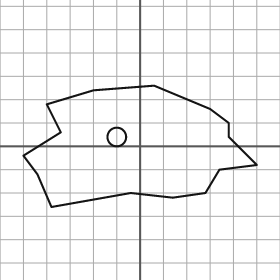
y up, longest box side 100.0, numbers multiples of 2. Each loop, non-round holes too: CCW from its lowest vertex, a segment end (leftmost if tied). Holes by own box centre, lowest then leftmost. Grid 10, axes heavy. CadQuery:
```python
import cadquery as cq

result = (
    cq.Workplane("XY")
    .moveTo(-38.0, -26.0)
    .lineTo(-4.0, -20.0)
    .lineTo(14.0, -22.0)
    .lineTo(28.0, -20.0)
    .lineTo(34.0, -10.0)
    .lineTo(50.0, -8.0)
    .lineTo(38.0, 4.0)
    .lineTo(38.0, 10.0)
    .lineTo(30.0, 16.0)
    .lineTo(6.0, 26.0)
    .lineTo(-20.0, 24.0)
    .lineTo(-40.0, 18.0)
    .lineTo(-34.0, 6.0)
    .lineTo(-50.0, -4.0)
    .lineTo(-44.0, -12.0)
    .close()
    .moveTo(-10.0, 4.0)
    .circle(4.0)
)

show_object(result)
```